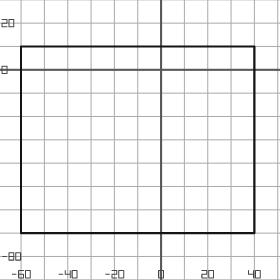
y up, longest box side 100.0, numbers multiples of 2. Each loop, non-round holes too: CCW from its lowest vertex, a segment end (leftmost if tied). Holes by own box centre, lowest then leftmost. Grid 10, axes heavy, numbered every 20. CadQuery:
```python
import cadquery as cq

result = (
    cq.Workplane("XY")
    .moveTo(-60.0, -70.0)
    .lineTo(40.0, -70.0)
    .lineTo(40.0, 10.0)
    .lineTo(-60.0, 10.0)
    .close()
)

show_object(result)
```